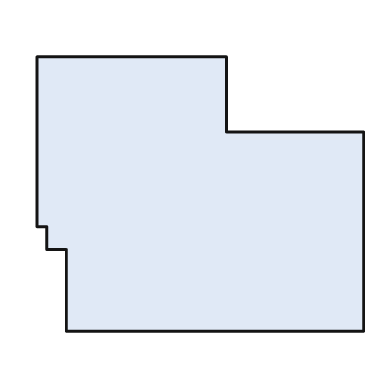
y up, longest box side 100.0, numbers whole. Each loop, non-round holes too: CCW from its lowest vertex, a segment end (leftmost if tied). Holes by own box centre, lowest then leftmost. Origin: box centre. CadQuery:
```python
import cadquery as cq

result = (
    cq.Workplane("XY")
    .moveTo(-41.0, -42.0)
    .lineTo(50.0, -42.0)
    .lineTo(50.0, 19.0)
    .lineTo(8.0, 19.0)
    .lineTo(8.0, 42.0)
    .lineTo(-50.0, 42.0)
    .lineTo(-50.0, -10.0)
    .lineTo(-47.0, -10.0)
    .lineTo(-47.0, -17.0)
    .lineTo(-41.0, -17.0)
    .close()
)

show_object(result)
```